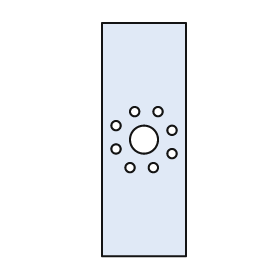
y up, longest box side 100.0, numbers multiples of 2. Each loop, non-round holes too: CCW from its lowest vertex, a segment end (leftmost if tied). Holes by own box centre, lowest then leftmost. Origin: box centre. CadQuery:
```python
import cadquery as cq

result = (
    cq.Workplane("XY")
    .moveTo(-18.0, -50.0)
    .lineTo(18.0, -50.0)
    .lineTo(18.0, 50.0)
    .lineTo(-18.0, 50.0)
    .close()
    .moveTo(-6.0, -12.0)
    .circle(2.0)
    .moveTo(4.0, -12.0)
    .circle(2.0)
    .moveTo(12.0, -6.0)
    .circle(2.0)
    .moveTo(-12.0, -4.0)
    .circle(2.0)
    .moveTo(0.0, 0.0)
    .circle(6.0)
    .moveTo(12.0, 4.0)
    .circle(2.0)
    .moveTo(-12.0, 6.0)
    .circle(2.0)
    .moveTo(-4.0, 12.0)
    .circle(2.0)
    .moveTo(6.0, 12.0)
    .circle(2.0)
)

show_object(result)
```